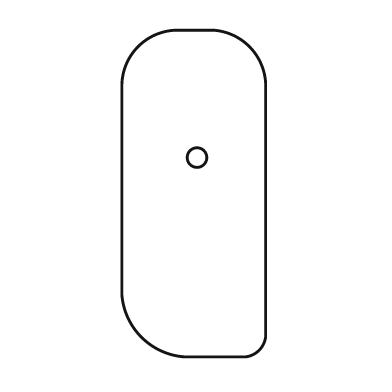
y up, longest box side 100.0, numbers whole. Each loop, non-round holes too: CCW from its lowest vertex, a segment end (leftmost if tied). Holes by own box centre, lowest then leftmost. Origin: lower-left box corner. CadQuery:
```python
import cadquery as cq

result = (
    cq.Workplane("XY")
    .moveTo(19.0, 0.0)
    .lineTo(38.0, 0.0)
    .threePointArc((42.0, 2.0), (44.0, 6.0))
    .lineTo(44.0, 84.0)
    .threePointArc((39.0, 95.0), (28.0, 100.0))
    .lineTo(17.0, 100.0)
    .threePointArc((5.0, 95.0), (0.0, 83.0))
    .lineTo(0.0, 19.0)
    .threePointArc((6.0, 6.0), (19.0, 0.0))
    .close()
    .moveTo(23.0, 61.0)
    .circle(3.0)
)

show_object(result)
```